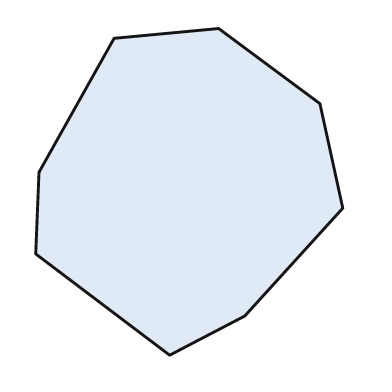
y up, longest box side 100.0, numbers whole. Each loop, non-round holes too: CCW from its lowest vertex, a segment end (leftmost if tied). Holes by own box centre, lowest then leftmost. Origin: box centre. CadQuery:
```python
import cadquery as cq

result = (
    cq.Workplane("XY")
    .moveTo(-6.0, -50.0)
    .lineTo(17.0, -38.0)
    .lineTo(47.0, -5.0)
    .lineTo(40.0, 27.0)
    .lineTo(9.0, 50.0)
    .lineTo(-23.0, 47.0)
    .lineTo(-46.0, 6.0)
    .lineTo(-47.0, -19.0)
    .close()
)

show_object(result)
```